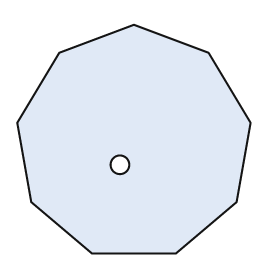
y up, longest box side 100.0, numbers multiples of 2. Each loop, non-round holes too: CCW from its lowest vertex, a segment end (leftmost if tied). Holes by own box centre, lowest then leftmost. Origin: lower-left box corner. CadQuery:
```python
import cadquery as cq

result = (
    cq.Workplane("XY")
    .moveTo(32.0, 0.0)
    .lineTo(68.0, 0.0)
    .lineTo(94.0, 22.0)
    .lineTo(100.0, 56.0)
    .lineTo(82.0, 86.0)
    .lineTo(50.0, 98.0)
    .lineTo(18.0, 86.0)
    .lineTo(0.0, 56.0)
    .lineTo(6.0, 22.0)
    .close()
    .moveTo(44.0, 38.0)
    .circle(4.0)
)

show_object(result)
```